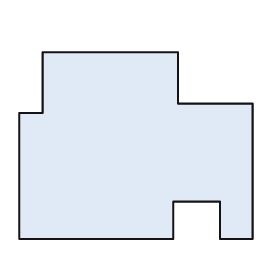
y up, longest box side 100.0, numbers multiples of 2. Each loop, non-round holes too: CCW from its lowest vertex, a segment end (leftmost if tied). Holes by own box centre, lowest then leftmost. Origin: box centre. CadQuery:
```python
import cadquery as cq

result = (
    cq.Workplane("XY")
    .moveTo(-50.0, -40.0)
    .lineTo(16.0, -40.0)
    .lineTo(16.0, -24.0)
    .lineTo(36.0, -24.0)
    .lineTo(36.0, -40.0)
    .lineTo(50.0, -40.0)
    .lineTo(50.0, 18.0)
    .lineTo(18.0, 18.0)
    .lineTo(18.0, 40.0)
    .lineTo(-40.0, 40.0)
    .lineTo(-40.0, 14.0)
    .lineTo(-50.0, 14.0)
    .close()
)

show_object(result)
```